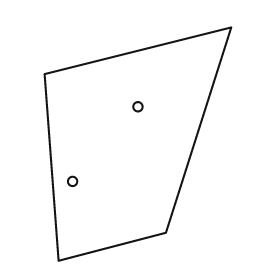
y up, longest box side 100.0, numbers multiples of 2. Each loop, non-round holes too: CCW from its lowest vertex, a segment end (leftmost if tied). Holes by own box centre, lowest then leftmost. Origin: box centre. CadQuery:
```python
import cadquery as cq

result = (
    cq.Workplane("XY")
    .moveTo(-34.0, -50.0)
    .lineTo(12.0, -38.0)
    .lineTo(40.0, 50.0)
    .lineTo(-40.0, 30.0)
    .close()
    .moveTo(-28.0, -16.0)
    .circle(2.0)
    .moveTo(0.0, 16.0)
    .circle(2.0)
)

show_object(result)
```